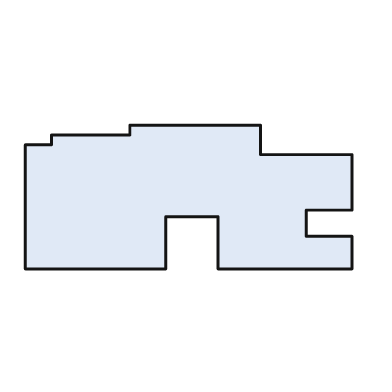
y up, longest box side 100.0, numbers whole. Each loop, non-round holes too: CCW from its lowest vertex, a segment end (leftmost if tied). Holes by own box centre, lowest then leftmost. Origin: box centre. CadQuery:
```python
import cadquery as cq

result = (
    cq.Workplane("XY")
    .moveTo(-50.0, -22.0)
    .lineTo(-7.0, -22.0)
    .lineTo(-7.0, -6.0)
    .lineTo(9.0, -6.0)
    .lineTo(9.0, -22.0)
    .lineTo(50.0, -22.0)
    .lineTo(50.0, -12.0)
    .lineTo(36.0, -12.0)
    .lineTo(36.0, -4.0)
    .lineTo(50.0, -4.0)
    .lineTo(50.0, 13.0)
    .lineTo(22.0, 13.0)
    .lineTo(22.0, 22.0)
    .lineTo(-18.0, 22.0)
    .lineTo(-18.0, 19.0)
    .lineTo(-42.0, 19.0)
    .lineTo(-42.0, 16.0)
    .lineTo(-50.0, 16.0)
    .close()
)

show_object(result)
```